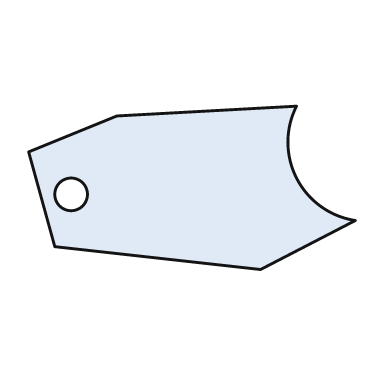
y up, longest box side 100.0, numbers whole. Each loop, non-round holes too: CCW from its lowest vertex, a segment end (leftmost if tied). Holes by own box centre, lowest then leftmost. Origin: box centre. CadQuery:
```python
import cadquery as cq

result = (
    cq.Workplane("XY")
    .moveTo(21.0, -25.0)
    .lineTo(50.0, -10.0)
    .threePointArc((32.0, 3.0), (32.0, 25.0))
    .lineTo(-23.0, 22.0)
    .lineTo(-50.0, 11.0)
    .lineTo(-42.0, -18.0)
    .close()
    .moveTo(-37.0, -2.0)
    .circle(5.0)
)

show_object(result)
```